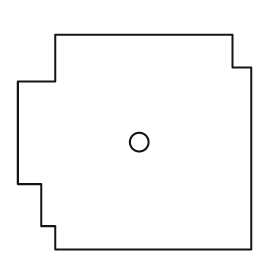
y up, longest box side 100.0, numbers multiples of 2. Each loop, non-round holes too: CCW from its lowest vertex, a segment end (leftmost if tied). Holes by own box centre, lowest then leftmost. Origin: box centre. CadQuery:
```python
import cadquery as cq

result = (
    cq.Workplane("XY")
    .moveTo(-34.0, -46.0)
    .lineTo(50.0, -46.0)
    .lineTo(50.0, 32.0)
    .lineTo(42.0, 32.0)
    .lineTo(42.0, 46.0)
    .lineTo(-34.0, 46.0)
    .lineTo(-34.0, 26.0)
    .lineTo(-50.0, 26.0)
    .lineTo(-50.0, -18.0)
    .lineTo(-40.0, -18.0)
    .lineTo(-40.0, -36.0)
    .lineTo(-34.0, -36.0)
    .close()
    .moveTo(2.0, 0.0)
    .circle(4.0)
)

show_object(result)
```